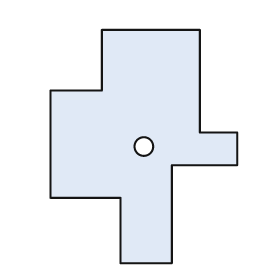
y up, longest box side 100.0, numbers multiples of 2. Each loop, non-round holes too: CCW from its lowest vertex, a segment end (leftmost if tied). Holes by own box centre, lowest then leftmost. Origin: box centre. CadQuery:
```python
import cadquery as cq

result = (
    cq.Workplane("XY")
    .moveTo(-10.0, -50.0)
    .lineTo(12.0, -50.0)
    .lineTo(12.0, -8.0)
    .lineTo(40.0, -8.0)
    .lineTo(40.0, 6.0)
    .lineTo(24.0, 6.0)
    .lineTo(24.0, 50.0)
    .lineTo(-18.0, 50.0)
    .lineTo(-18.0, 24.0)
    .lineTo(-40.0, 24.0)
    .lineTo(-40.0, -22.0)
    .lineTo(-10.0, -22.0)
    .close()
    .moveTo(0.0, 0.0)
    .circle(4.0)
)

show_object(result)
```